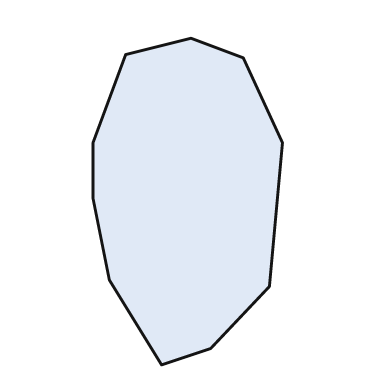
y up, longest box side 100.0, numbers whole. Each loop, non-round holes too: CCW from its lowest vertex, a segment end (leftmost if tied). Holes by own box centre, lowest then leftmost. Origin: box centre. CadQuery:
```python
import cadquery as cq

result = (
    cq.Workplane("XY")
    .moveTo(-8.0, -50.0)
    .lineTo(7.0, -45.0)
    .lineTo(25.0, -26.0)
    .lineTo(29.0, 18.0)
    .lineTo(17.0, 44.0)
    .lineTo(1.0, 50.0)
    .lineTo(-19.0, 45.0)
    .lineTo(-29.0, 18.0)
    .lineTo(-29.0, 1.0)
    .lineTo(-24.0, -24.0)
    .close()
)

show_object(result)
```